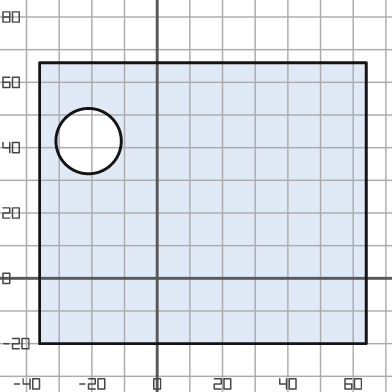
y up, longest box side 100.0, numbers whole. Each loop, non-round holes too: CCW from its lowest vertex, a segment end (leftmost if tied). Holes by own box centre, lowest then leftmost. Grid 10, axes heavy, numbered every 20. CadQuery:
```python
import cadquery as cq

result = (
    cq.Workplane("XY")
    .moveTo(-36.0, -20.0)
    .lineTo(64.0, -20.0)
    .lineTo(64.0, 66.0)
    .lineTo(-36.0, 66.0)
    .close()
    .moveTo(-21.0, 42.0)
    .circle(10.0)
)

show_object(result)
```